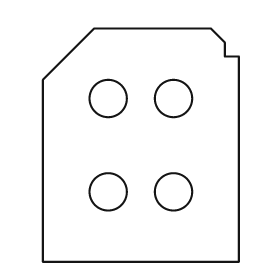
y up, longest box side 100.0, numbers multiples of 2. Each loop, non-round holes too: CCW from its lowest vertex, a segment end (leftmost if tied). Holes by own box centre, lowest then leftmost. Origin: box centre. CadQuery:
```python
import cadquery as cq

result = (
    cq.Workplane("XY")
    .moveTo(-42.0, -50.0)
    .lineTo(42.0, -50.0)
    .lineTo(42.0, 38.0)
    .lineTo(36.0, 38.0)
    .lineTo(36.0, 44.0)
    .lineTo(30.0, 50.0)
    .lineTo(-20.0, 50.0)
    .lineTo(-42.0, 28.0)
    .close()
    .moveTo(-14.0, -20.0)
    .circle(8.0)
    .moveTo(14.0, -20.0)
    .circle(8.0)
    .moveTo(-14.0, 20.0)
    .circle(8.0)
    .moveTo(14.0, 20.0)
    .circle(8.0)
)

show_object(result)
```